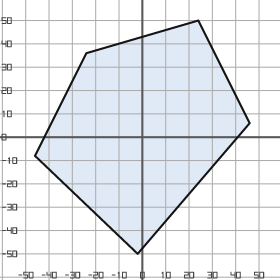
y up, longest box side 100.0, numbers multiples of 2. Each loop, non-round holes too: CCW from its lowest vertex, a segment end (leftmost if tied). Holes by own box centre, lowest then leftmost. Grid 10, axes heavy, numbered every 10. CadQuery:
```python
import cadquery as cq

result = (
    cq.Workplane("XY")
    .moveTo(-2.0, -50.0)
    .lineTo(46.0, 6.0)
    .lineTo(24.0, 50.0)
    .lineTo(-24.0, 36.0)
    .lineTo(-46.0, -8.0)
    .close()
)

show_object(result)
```